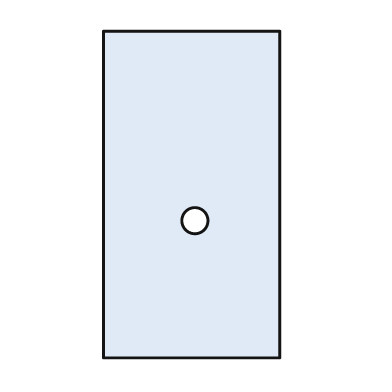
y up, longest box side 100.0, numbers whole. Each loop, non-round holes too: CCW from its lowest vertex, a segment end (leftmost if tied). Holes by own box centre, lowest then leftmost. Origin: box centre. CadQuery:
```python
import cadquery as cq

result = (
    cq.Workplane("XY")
    .moveTo(-27.0, -50.0)
    .lineTo(27.0, -50.0)
    .lineTo(27.0, 50.0)
    .lineTo(-27.0, 50.0)
    .close()
    .moveTo(1.0, -8.0)
    .circle(4.0)
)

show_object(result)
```